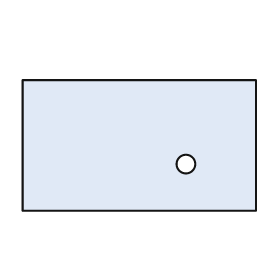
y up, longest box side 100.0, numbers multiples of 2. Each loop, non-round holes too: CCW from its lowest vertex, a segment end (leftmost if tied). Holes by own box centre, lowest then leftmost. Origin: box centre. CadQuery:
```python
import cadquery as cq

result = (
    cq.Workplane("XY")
    .moveTo(-50.0, -28.0)
    .lineTo(50.0, -28.0)
    .lineTo(50.0, 28.0)
    .lineTo(-50.0, 28.0)
    .close()
    .moveTo(20.0, -8.0)
    .circle(4.0)
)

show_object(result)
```